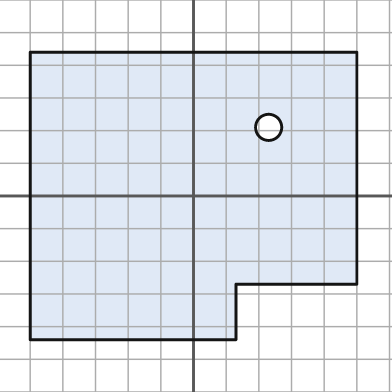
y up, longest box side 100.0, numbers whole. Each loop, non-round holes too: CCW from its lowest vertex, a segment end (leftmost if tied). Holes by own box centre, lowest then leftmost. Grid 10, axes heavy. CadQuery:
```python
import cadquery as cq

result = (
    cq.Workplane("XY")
    .moveTo(-50.0, -44.0)
    .lineTo(13.0, -44.0)
    .lineTo(13.0, -27.0)
    .lineTo(50.0, -27.0)
    .lineTo(50.0, 44.0)
    .lineTo(-50.0, 44.0)
    .close()
    .moveTo(23.0, 21.0)
    .circle(4.0)
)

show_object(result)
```